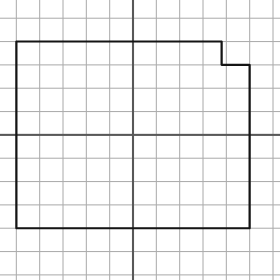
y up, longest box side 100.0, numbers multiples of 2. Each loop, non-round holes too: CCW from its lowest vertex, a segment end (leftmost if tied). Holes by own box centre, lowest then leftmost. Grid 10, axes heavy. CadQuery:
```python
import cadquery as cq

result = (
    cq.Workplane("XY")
    .moveTo(-50.0, -40.0)
    .lineTo(50.0, -40.0)
    .lineTo(50.0, 30.0)
    .lineTo(38.0, 30.0)
    .lineTo(38.0, 40.0)
    .lineTo(-50.0, 40.0)
    .close()
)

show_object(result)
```